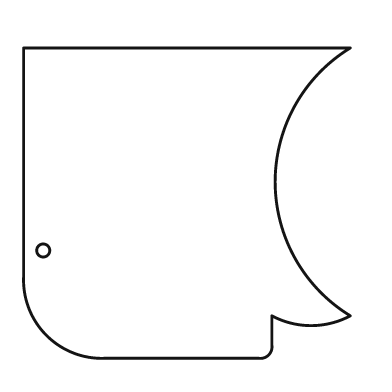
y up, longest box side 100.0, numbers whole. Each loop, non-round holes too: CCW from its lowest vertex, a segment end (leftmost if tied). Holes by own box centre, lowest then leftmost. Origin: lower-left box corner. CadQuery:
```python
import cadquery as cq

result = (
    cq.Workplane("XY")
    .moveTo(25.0, 0.0)
    .lineTo(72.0, 0.0)
    .threePointArc((75.0, 1.0), (76.0, 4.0))
    .lineTo(76.0, 13.0)
    .threePointArc((88.0, 10.0), (100.0, 13.0))
    .threePointArc((77.0, 54.0), (100.0, 95.0))
    .lineTo(0.0, 95.0)
    .lineTo(0.0, 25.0)
    .threePointArc((7.0, 7.0), (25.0, 0.0))
    .close()
    .moveTo(6.0, 33.0)
    .circle(2.0)
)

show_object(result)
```